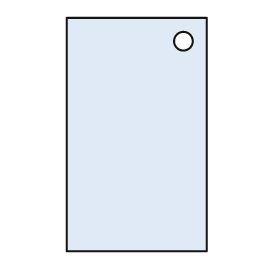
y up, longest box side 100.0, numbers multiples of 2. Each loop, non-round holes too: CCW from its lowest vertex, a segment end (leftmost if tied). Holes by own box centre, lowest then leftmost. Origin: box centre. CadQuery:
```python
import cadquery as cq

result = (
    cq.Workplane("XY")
    .moveTo(-30.0, -50.0)
    .lineTo(30.0, -50.0)
    .lineTo(30.0, 50.0)
    .lineTo(-30.0, 50.0)
    .close()
    .moveTo(20.0, 40.0)
    .circle(4.0)
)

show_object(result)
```